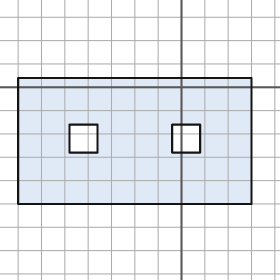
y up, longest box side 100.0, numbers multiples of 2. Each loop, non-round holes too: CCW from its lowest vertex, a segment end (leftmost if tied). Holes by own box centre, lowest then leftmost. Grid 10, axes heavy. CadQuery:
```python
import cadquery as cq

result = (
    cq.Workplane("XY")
    .moveTo(-70.0, -50.0)
    .lineTo(30.0, -50.0)
    .lineTo(30.0, 4.0)
    .lineTo(-70.0, 4.0)
    .close()
    .moveTo(-48.0, -28.0)
    .lineTo(-36.0, -28.0)
    .lineTo(-36.0, -16.0)
    .lineTo(-48.0, -16.0)
    .close()
    .moveTo(-4.0, -28.0)
    .lineTo(8.0, -28.0)
    .lineTo(8.0, -16.0)
    .lineTo(-4.0, -16.0)
    .close()
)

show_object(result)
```